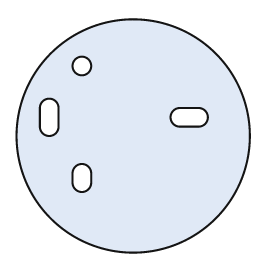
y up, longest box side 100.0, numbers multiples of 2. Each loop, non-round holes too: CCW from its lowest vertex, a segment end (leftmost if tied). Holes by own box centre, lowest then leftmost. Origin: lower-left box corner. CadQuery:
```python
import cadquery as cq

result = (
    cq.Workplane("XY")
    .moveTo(50.0, 50.0)
    .circle(50.0)
    .moveTo(24.0, 30.0)
    .threePointArc((28.0, 26.0), (32.0, 30.0))
    .lineTo(32.0, 34.0)
    .threePointArc((28.0, 38.0), (24.0, 34.0))
    .close()
    .moveTo(10.0, 54.0)
    .threePointArc((14.0, 50.0), (18.0, 54.0))
    .lineTo(18.0, 62.0)
    .threePointArc((14.0, 66.0), (10.0, 62.0))
    .close()
    .moveTo(70.0, 54.0)
    .lineTo(78.0, 54.0)
    .threePointArc((82.0, 58.0), (78.0, 62.0))
    .lineTo(70.0, 62.0)
    .threePointArc((66.0, 58.0), (70.0, 54.0))
    .close()
    .moveTo(28.0, 80.0)
    .circle(4.0)
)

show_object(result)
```